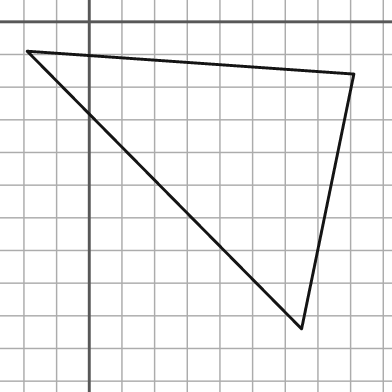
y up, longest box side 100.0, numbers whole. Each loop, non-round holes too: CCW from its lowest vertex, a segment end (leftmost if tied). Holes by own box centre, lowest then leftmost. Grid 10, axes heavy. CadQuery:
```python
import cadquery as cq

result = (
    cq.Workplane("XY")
    .moveTo(65.0, -94.0)
    .lineTo(81.0, -16.0)
    .lineTo(-19.0, -9.0)
    .close()
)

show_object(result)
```